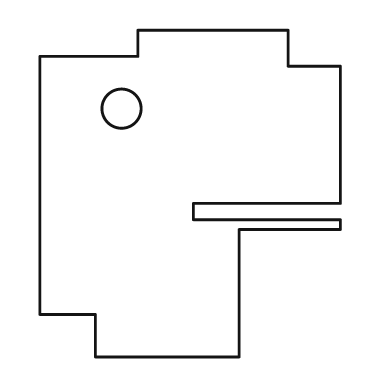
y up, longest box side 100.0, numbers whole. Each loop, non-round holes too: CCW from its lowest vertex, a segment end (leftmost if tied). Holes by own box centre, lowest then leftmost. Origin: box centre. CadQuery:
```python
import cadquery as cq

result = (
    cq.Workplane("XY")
    .moveTo(-29.0, -50.0)
    .lineTo(15.0, -50.0)
    .lineTo(15.0, -11.0)
    .lineTo(46.0, -11.0)
    .lineTo(46.0, -8.0)
    .lineTo(1.0, -8.0)
    .lineTo(1.0, -3.0)
    .lineTo(46.0, -3.0)
    .lineTo(46.0, 39.0)
    .lineTo(30.0, 39.0)
    .lineTo(30.0, 50.0)
    .lineTo(-16.0, 50.0)
    .lineTo(-16.0, 42.0)
    .lineTo(-46.0, 42.0)
    .lineTo(-46.0, -37.0)
    .lineTo(-29.0, -37.0)
    .close()
    .moveTo(-21.0, 26.0)
    .circle(6.0)
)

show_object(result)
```